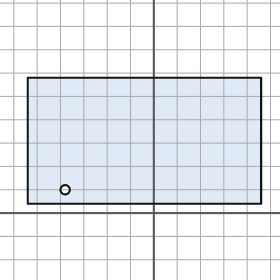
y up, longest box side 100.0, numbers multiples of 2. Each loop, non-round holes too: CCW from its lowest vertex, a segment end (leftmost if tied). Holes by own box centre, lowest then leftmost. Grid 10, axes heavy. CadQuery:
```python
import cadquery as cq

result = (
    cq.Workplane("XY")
    .moveTo(-54.0, 4.0)
    .lineTo(46.0, 4.0)
    .lineTo(46.0, 58.0)
    .lineTo(-54.0, 58.0)
    .close()
    .moveTo(-38.0, 10.0)
    .circle(2.0)
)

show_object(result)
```